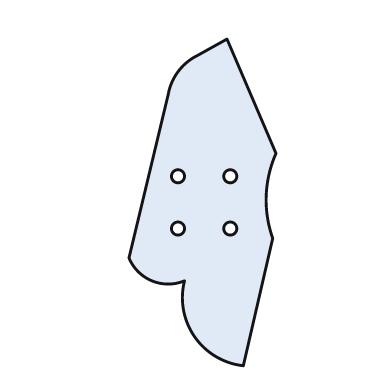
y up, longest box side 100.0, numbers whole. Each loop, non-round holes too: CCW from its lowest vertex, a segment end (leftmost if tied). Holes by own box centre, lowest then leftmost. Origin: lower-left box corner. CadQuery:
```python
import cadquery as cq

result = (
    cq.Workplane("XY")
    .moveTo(35.0, 0.0)
    .lineTo(44.0, 39.0)
    .threePointArc((42.0, 52.0), (45.0, 65.0))
    .lineTo(30.0, 100.0)
    .lineTo(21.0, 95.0)
    .threePointArc((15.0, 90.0), (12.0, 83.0))
    .lineTo(0.0, 33.0)
    .threePointArc((7.0, 26.0), (17.0, 26.0))
    .threePointArc((20.0, 9.0), (35.0, 0.0))
    .close()
    .moveTo(15.0, 42.0)
    .circle(2.0)
    .moveTo(31.0, 42.0)
    .circle(2.0)
    .moveTo(15.0, 58.0)
    .circle(2.0)
    .moveTo(31.0, 58.0)
    .circle(2.0)
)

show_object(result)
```